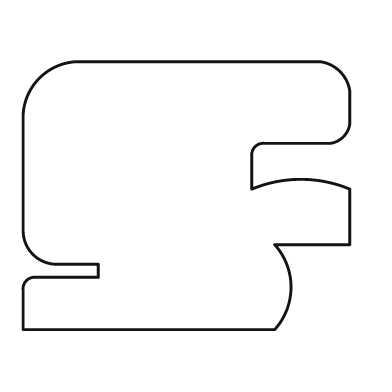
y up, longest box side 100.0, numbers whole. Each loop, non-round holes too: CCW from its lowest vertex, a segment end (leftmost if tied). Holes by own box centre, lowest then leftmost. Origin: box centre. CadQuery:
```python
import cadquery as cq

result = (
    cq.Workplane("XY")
    .moveTo(-50.0, -41.0)
    .lineTo(27.0, -41.0)
    .threePointArc((32.0, -28.0), (27.0, -15.0))
    .lineTo(50.0, -15.0)
    .lineTo(50.0, 2.0)
    .threePointArc((35.0, 5.0), (20.0, 2.0))
    .lineTo(20.0, 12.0)
    .threePointArc((21.0, 15.0), (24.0, 16.0))
    .lineTo(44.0, 16.0)
    .threePointArc((48.0, 18.0), (50.0, 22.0))
    .lineTo(50.0, 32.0)
    .threePointArc((47.0, 38.0), (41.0, 41.0))
    .lineTo(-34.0, 41.0)
    .threePointArc((-45.0, 36.0), (-50.0, 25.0))
    .lineTo(-50.0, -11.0)
    .threePointArc((-47.0, -18.0), (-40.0, -21.0))
    .lineTo(-27.0, -21.0)
    .lineTo(-27.0, -25.0)
    .lineTo(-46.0, -25.0)
    .threePointArc((-49.0, -26.0), (-50.0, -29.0))
    .close()
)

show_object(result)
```